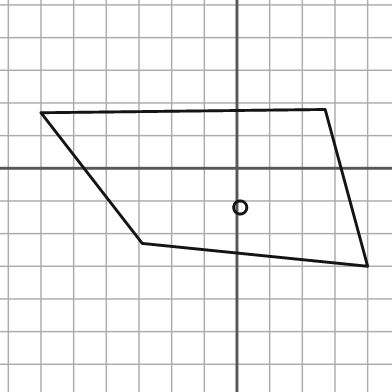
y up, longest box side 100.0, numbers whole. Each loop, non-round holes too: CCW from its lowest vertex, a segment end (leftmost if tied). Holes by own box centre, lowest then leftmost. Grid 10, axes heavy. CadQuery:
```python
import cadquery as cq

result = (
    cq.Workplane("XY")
    .moveTo(40.0, -30.0)
    .lineTo(27.0, 18.0)
    .lineTo(-60.0, 17.0)
    .lineTo(-29.0, -23.0)
    .close()
    .moveTo(1.0, -12.0)
    .circle(2.0)
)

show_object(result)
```